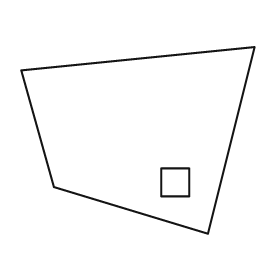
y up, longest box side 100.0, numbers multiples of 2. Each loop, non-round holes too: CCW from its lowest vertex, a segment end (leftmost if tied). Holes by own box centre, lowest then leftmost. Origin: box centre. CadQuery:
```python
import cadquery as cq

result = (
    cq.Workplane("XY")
    .moveTo(30.0, -40.0)
    .lineTo(50.0, 40.0)
    .lineTo(-50.0, 30.0)
    .lineTo(-36.0, -20.0)
    .close()
    .moveTo(10.0, -24.0)
    .lineTo(22.0, -24.0)
    .lineTo(22.0, -12.0)
    .lineTo(10.0, -12.0)
    .close()
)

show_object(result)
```